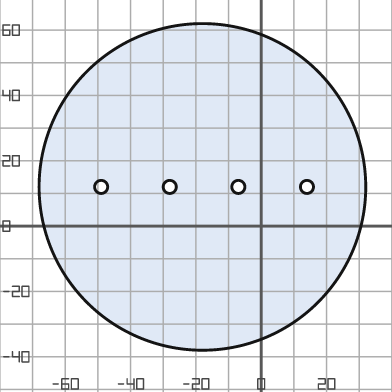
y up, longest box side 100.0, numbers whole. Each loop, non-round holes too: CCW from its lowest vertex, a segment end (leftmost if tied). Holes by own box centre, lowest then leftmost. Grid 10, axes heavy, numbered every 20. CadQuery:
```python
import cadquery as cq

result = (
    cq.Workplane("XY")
    .moveTo(-18.0, 12.0)
    .circle(50.0)
    .moveTo(-49.0, 12.0)
    .circle(2.0)
    .moveTo(-28.0, 12.0)
    .circle(2.0)
    .moveTo(-7.0, 12.0)
    .circle(2.0)
    .moveTo(14.0, 12.0)
    .circle(2.0)
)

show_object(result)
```